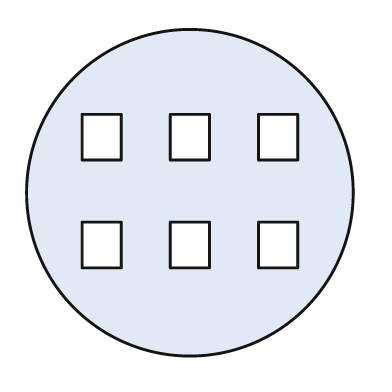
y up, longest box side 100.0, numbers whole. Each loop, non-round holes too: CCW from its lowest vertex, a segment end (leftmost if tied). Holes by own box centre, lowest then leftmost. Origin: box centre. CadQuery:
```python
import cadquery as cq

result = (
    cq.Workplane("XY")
    .moveTo(0.0, 0.0)
    .circle(50.0)
    .moveTo(-33.0, -23.0)
    .lineTo(-21.0, -23.0)
    .lineTo(-21.0, -9.0)
    .lineTo(-33.0, -9.0)
    .close()
    .moveTo(-6.0, -23.0)
    .lineTo(6.0, -23.0)
    .lineTo(6.0, -9.0)
    .lineTo(-6.0, -9.0)
    .close()
    .moveTo(21.0, -23.0)
    .lineTo(33.0, -23.0)
    .lineTo(33.0, -9.0)
    .lineTo(21.0, -9.0)
    .close()
    .moveTo(-33.0, 10.0)
    .lineTo(-21.0, 10.0)
    .lineTo(-21.0, 24.0)
    .lineTo(-33.0, 24.0)
    .close()
    .moveTo(-6.0, 10.0)
    .lineTo(6.0, 10.0)
    .lineTo(6.0, 24.0)
    .lineTo(-6.0, 24.0)
    .close()
    .moveTo(21.0, 10.0)
    .lineTo(33.0, 10.0)
    .lineTo(33.0, 24.0)
    .lineTo(21.0, 24.0)
    .close()
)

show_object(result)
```